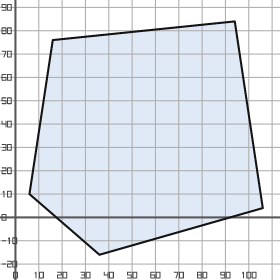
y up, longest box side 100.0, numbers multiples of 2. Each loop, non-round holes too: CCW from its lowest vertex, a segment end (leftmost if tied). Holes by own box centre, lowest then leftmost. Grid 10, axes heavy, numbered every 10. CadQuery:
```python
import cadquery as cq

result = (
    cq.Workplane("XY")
    .moveTo(36.0, -16.0)
    .lineTo(106.0, 4.0)
    .lineTo(94.0, 84.0)
    .lineTo(16.0, 76.0)
    .lineTo(6.0, 10.0)
    .close()
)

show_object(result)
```